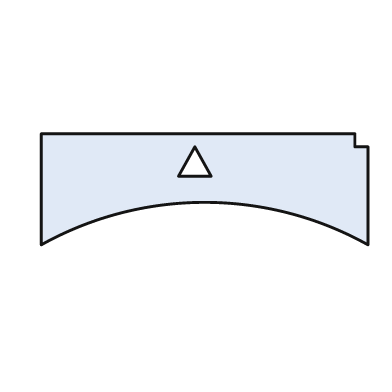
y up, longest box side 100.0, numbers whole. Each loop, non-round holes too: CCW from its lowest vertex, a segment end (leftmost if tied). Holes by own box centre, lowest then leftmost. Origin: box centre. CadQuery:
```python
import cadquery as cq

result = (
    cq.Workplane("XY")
    .moveTo(-50.0, -17.0)
    .threePointArc((0.0, -4.0), (50.0, -17.0))
    .lineTo(50.0, 13.0)
    .lineTo(46.0, 13.0)
    .lineTo(46.0, 17.0)
    .lineTo(-50.0, 17.0)
    .close()
    .moveTo(-8.0, 4.0)
    .lineTo(2.0, 4.0)
    .lineTo(-3.0, 13.0)
    .close()
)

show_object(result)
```